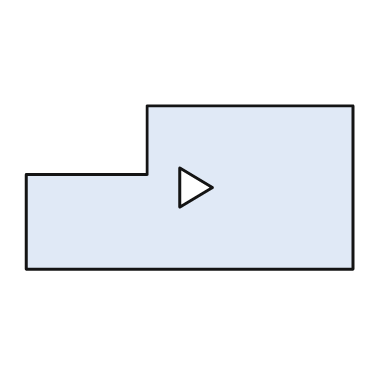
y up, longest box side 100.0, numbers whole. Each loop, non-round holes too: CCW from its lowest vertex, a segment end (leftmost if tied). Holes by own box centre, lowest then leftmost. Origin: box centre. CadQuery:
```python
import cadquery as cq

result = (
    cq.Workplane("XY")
    .moveTo(-50.0, -25.0)
    .lineTo(50.0, -25.0)
    .lineTo(50.0, 25.0)
    .lineTo(-13.0, 25.0)
    .lineTo(-13.0, 4.0)
    .lineTo(-50.0, 4.0)
    .close()
    .moveTo(-3.0, -6.0)
    .lineTo(7.0, 0.0)
    .lineTo(-3.0, 6.0)
    .close()
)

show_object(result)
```